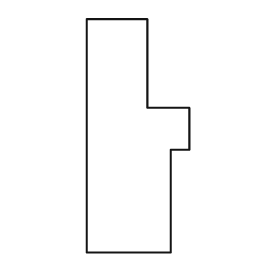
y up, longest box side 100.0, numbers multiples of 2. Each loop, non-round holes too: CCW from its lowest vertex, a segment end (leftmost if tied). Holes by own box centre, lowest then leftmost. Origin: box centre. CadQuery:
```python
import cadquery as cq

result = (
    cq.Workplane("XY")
    .moveTo(-22.0, -50.0)
    .lineTo(14.0, -50.0)
    .lineTo(14.0, -6.0)
    .lineTo(22.0, -6.0)
    .lineTo(22.0, 12.0)
    .lineTo(4.0, 12.0)
    .lineTo(4.0, 50.0)
    .lineTo(-22.0, 50.0)
    .close()
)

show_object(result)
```